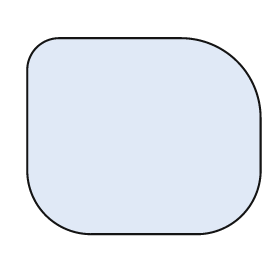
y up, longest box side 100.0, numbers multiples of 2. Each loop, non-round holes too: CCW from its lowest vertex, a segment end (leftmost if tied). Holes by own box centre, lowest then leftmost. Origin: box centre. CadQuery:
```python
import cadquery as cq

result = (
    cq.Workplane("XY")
    .moveTo(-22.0, -42.0)
    .lineTo(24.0, -42.0)
    .threePointArc((42.0, -34.0), (50.0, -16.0))
    .lineTo(50.0, 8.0)
    .threePointArc((40.0, 32.0), (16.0, 42.0))
    .lineTo(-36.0, 42.0)
    .threePointArc((-46.0, 38.0), (-50.0, 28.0))
    .lineTo(-50.0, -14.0)
    .threePointArc((-42.0, -34.0), (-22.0, -42.0))
    .close()
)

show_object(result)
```